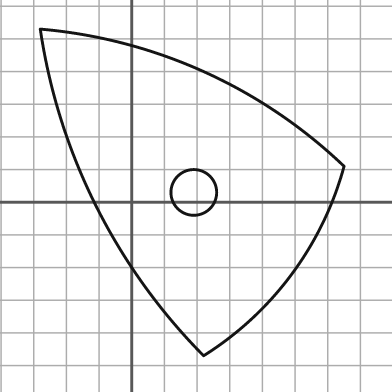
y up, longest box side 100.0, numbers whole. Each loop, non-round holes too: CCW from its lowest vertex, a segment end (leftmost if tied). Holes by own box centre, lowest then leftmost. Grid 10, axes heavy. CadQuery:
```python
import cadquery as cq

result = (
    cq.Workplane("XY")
    .moveTo(22.0, -47.0)
    .threePointArc((49.0, -22.0), (65.0, 11.0))
    .threePointArc((22.0, 40.0), (-28.0, 53.0))
    .threePointArc((-11.0, -1.0), (22.0, -47.0))
    .close()
    .moveTo(19.0, 3.0)
    .circle(7.0)
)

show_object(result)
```